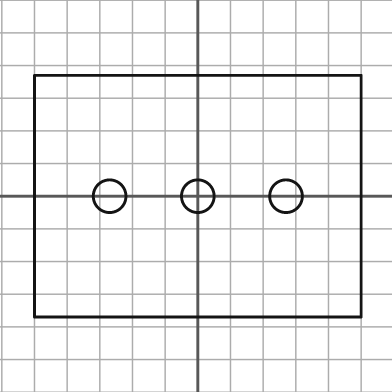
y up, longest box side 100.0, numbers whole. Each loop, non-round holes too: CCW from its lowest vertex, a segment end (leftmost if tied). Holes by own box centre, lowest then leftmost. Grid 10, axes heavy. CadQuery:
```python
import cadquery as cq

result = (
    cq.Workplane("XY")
    .moveTo(-50.0, -37.0)
    .lineTo(50.0, -37.0)
    .lineTo(50.0, 37.0)
    .lineTo(-50.0, 37.0)
    .close()
    .moveTo(-27.0, 0.0)
    .circle(5.0)
    .moveTo(0.0, 0.0)
    .circle(5.0)
    .moveTo(27.0, 0.0)
    .circle(5.0)
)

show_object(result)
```